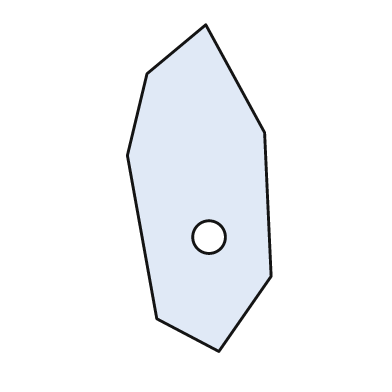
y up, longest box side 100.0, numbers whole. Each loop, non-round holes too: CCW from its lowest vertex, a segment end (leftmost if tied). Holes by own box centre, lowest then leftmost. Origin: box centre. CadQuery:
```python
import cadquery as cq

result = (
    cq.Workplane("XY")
    .moveTo(6.0, -50.0)
    .lineTo(22.0, -27.0)
    .lineTo(20.0, 17.0)
    .lineTo(2.0, 50.0)
    .lineTo(-16.0, 35.0)
    .lineTo(-22.0, 10.0)
    .lineTo(-13.0, -40.0)
    .close()
    .moveTo(3.0, -15.0)
    .circle(5.0)
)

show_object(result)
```